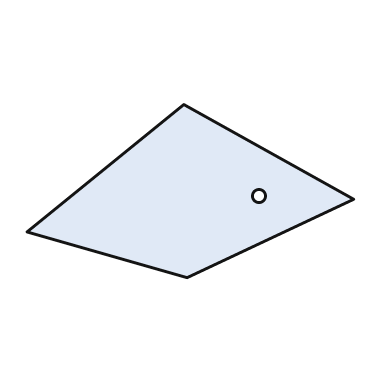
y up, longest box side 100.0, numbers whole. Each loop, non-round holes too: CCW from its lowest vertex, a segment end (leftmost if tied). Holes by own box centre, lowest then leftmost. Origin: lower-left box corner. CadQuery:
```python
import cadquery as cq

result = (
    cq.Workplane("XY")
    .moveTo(49.0, 0.0)
    .lineTo(100.0, 24.0)
    .lineTo(48.0, 53.0)
    .lineTo(0.0, 14.0)
    .close()
    .moveTo(71.0, 25.0)
    .circle(2.0)
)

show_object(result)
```